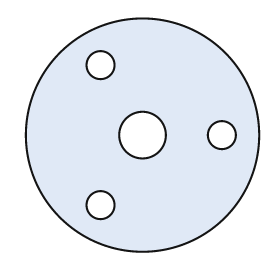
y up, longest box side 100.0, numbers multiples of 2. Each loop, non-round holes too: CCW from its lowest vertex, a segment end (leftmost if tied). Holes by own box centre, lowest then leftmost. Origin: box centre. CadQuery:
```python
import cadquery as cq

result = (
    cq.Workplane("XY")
    .moveTo(0.0, 0.0)
    .circle(50.0)
    .moveTo(-18.0, -30.0)
    .circle(6.0)
    .moveTo(0.0, 0.0)
    .circle(10.0)
    .moveTo(34.0, 0.0)
    .circle(6.0)
    .moveTo(-18.0, 30.0)
    .circle(6.0)
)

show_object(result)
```